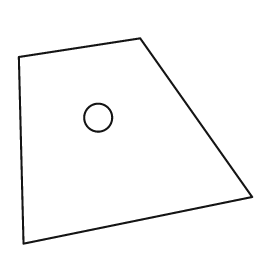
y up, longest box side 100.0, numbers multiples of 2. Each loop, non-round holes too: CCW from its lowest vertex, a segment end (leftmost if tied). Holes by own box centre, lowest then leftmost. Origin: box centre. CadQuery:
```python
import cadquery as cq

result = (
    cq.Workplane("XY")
    .moveTo(-48.0, -44.0)
    .lineTo(50.0, -24.0)
    .lineTo(2.0, 44.0)
    .lineTo(-50.0, 36.0)
    .close()
    .moveTo(-16.0, 10.0)
    .circle(6.0)
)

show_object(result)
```